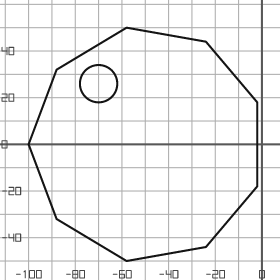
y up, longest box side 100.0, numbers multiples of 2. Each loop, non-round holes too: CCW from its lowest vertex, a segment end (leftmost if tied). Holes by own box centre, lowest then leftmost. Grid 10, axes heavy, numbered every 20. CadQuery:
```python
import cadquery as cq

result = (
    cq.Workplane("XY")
    .moveTo(-58.0, -50.0)
    .lineTo(-24.0, -44.0)
    .lineTo(-2.0, -18.0)
    .lineTo(-2.0, 18.0)
    .lineTo(-24.0, 44.0)
    .lineTo(-58.0, 50.0)
    .lineTo(-88.0, 32.0)
    .lineTo(-100.0, 0.0)
    .lineTo(-88.0, -32.0)
    .close()
    .moveTo(-70.0, 26.0)
    .circle(8.0)
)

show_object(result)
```